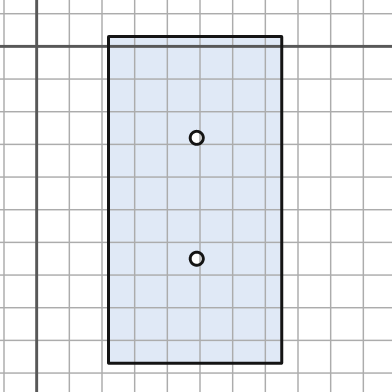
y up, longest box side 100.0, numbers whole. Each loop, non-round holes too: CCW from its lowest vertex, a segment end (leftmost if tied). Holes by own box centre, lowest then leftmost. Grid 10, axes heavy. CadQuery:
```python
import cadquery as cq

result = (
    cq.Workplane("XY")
    .moveTo(22.0, -97.0)
    .lineTo(75.0, -97.0)
    .lineTo(75.0, 3.0)
    .lineTo(22.0, 3.0)
    .close()
    .moveTo(49.0, -65.0)
    .circle(2.0)
    .moveTo(49.0, -28.0)
    .circle(2.0)
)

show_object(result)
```